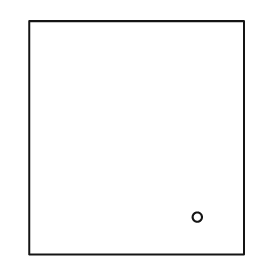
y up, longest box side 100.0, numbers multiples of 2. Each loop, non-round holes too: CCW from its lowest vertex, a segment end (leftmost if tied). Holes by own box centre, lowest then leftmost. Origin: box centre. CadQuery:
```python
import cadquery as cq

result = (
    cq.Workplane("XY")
    .moveTo(-46.0, -50.0)
    .lineTo(46.0, -50.0)
    .lineTo(46.0, 50.0)
    .lineTo(-46.0, 50.0)
    .close()
    .moveTo(26.0, -34.0)
    .circle(2.0)
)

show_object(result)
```